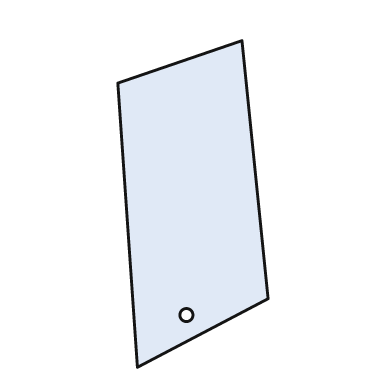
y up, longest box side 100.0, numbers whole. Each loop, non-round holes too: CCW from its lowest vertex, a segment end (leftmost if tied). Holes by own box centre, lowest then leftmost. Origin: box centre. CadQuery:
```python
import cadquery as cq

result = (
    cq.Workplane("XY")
    .moveTo(-17.0, -50.0)
    .lineTo(23.0, -29.0)
    .lineTo(15.0, 50.0)
    .lineTo(-23.0, 37.0)
    .close()
    .moveTo(-2.0, -34.0)
    .circle(2.0)
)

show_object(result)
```